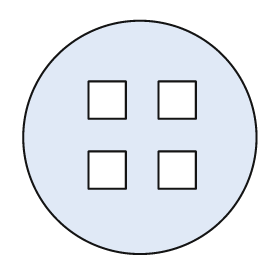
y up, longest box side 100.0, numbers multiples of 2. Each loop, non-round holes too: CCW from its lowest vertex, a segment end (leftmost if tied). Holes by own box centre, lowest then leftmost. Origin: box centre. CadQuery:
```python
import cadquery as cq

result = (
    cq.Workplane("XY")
    .moveTo(0.0, 0.0)
    .circle(50.0)
    .moveTo(-22.0, -22.0)
    .lineTo(-6.0, -22.0)
    .lineTo(-6.0, -6.0)
    .lineTo(-22.0, -6.0)
    .close()
    .moveTo(8.0, -22.0)
    .lineTo(24.0, -22.0)
    .lineTo(24.0, -6.0)
    .lineTo(8.0, -6.0)
    .close()
    .moveTo(-22.0, 8.0)
    .lineTo(-6.0, 8.0)
    .lineTo(-6.0, 24.0)
    .lineTo(-22.0, 24.0)
    .close()
    .moveTo(8.0, 8.0)
    .lineTo(24.0, 8.0)
    .lineTo(24.0, 24.0)
    .lineTo(8.0, 24.0)
    .close()
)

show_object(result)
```